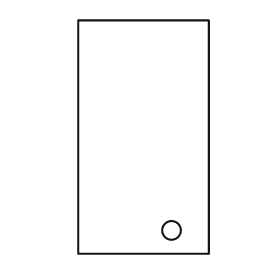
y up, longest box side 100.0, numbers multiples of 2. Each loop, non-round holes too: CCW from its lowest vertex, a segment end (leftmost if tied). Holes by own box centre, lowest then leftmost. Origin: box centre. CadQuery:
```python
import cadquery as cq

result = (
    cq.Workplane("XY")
    .moveTo(-28.0, -50.0)
    .lineTo(28.0, -50.0)
    .lineTo(28.0, 50.0)
    .lineTo(-28.0, 50.0)
    .close()
    .moveTo(12.0, -40.0)
    .circle(4.0)
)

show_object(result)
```